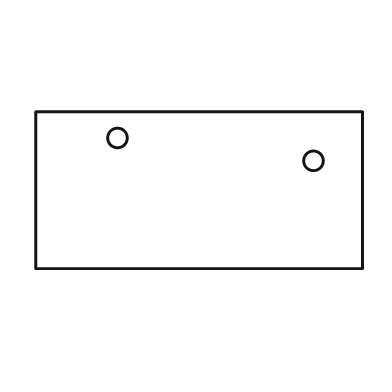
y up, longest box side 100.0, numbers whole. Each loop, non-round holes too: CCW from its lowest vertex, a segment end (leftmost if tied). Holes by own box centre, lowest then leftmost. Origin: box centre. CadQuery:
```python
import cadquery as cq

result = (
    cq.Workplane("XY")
    .moveTo(-50.0, -24.0)
    .lineTo(50.0, -24.0)
    .lineTo(50.0, 24.0)
    .lineTo(-50.0, 24.0)
    .close()
    .moveTo(35.0, 9.0)
    .circle(3.0)
    .moveTo(-25.0, 16.0)
    .circle(3.0)
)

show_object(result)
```